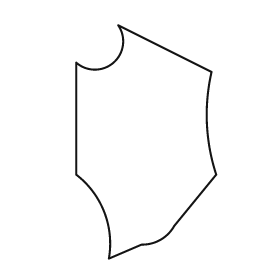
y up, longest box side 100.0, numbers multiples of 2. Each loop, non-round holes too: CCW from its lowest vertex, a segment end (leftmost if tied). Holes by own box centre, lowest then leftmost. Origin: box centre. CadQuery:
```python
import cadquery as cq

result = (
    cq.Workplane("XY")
    .moveTo(-16.0, -50.0)
    .lineTo(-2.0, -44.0)
    .threePointArc((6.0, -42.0), (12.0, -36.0))
    .lineTo(30.0, -14.0)
    .threePointArc((26.0, 8.0), (28.0, 30.0))
    .lineTo(-12.0, 50.0)
    .threePointArc((-14.0, 34.0), (-30.0, 34.0))
    .lineTo(-30.0, -14.0)
    .threePointArc((-18.0, -30.0), (-16.0, -50.0))
    .close()
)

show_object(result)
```